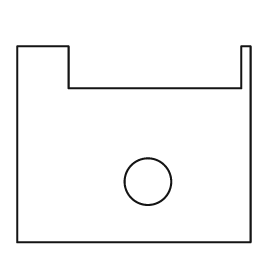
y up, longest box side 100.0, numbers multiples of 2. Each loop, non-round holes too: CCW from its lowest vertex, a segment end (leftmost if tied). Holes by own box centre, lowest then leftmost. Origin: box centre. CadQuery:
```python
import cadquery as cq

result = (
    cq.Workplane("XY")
    .moveTo(-50.0, -42.0)
    .lineTo(50.0, -42.0)
    .lineTo(50.0, 42.0)
    .lineTo(46.0, 42.0)
    .lineTo(46.0, 24.0)
    .lineTo(-28.0, 24.0)
    .lineTo(-28.0, 42.0)
    .lineTo(-50.0, 42.0)
    .close()
    .moveTo(6.0, -16.0)
    .circle(10.0)
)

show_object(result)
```